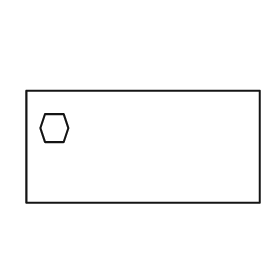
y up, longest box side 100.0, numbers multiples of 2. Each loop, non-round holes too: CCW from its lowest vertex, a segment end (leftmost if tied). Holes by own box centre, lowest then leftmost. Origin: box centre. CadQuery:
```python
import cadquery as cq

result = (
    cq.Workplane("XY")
    .moveTo(-50.0, -24.0)
    .lineTo(50.0, -24.0)
    .lineTo(50.0, 24.0)
    .lineTo(-50.0, 24.0)
    .close()
    .moveTo(-42.0, 2.0)
    .lineTo(-34.0, 2.0)
    .lineTo(-32.0, 8.0)
    .lineTo(-34.0, 14.0)
    .lineTo(-42.0, 14.0)
    .lineTo(-44.0, 8.0)
    .close()
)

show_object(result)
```